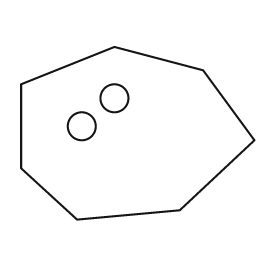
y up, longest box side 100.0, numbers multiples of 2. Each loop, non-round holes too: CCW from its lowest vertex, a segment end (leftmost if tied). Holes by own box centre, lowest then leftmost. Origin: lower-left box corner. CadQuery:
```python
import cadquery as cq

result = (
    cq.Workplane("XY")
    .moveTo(24.0, 0.0)
    .lineTo(68.0, 4.0)
    .lineTo(100.0, 34.0)
    .lineTo(78.0, 64.0)
    .lineTo(40.0, 74.0)
    .lineTo(0.0, 58.0)
    .lineTo(0.0, 22.0)
    .close()
    .moveTo(26.0, 40.0)
    .circle(6.0)
    .moveTo(40.0, 52.0)
    .circle(6.0)
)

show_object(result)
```